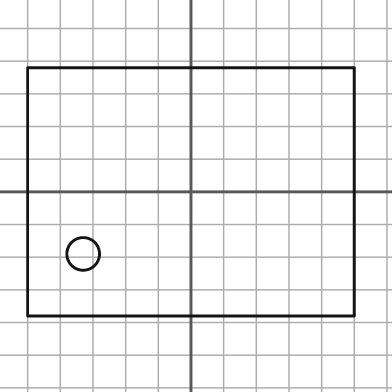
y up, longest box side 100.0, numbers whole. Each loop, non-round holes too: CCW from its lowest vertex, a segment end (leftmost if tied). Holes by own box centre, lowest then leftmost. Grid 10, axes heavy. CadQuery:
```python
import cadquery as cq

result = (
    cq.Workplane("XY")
    .moveTo(-50.0, -38.0)
    .lineTo(50.0, -38.0)
    .lineTo(50.0, 38.0)
    .lineTo(-50.0, 38.0)
    .close()
    .moveTo(-33.0, -19.0)
    .circle(5.0)
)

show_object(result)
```